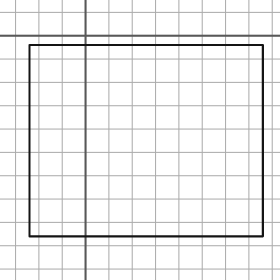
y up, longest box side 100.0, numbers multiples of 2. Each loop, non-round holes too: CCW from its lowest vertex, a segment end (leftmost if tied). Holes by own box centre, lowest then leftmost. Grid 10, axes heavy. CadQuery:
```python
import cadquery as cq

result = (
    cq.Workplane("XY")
    .moveTo(-24.0, -86.0)
    .lineTo(76.0, -86.0)
    .lineTo(76.0, -4.0)
    .lineTo(-24.0, -4.0)
    .close()
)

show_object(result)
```